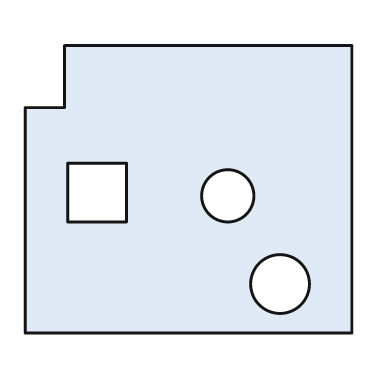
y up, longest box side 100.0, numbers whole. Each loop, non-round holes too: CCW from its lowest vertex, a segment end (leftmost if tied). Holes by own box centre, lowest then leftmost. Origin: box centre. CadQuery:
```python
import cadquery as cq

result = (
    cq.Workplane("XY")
    .moveTo(-50.0, -44.0)
    .lineTo(50.0, -44.0)
    .lineTo(50.0, 44.0)
    .lineTo(-38.0, 44.0)
    .lineTo(-38.0, 25.0)
    .lineTo(-50.0, 25.0)
    .close()
    .moveTo(28.0, -29.0)
    .circle(9.0)
    .moveTo(12.0, -2.0)
    .circle(8.0)
    .moveTo(-37.0, -10.0)
    .lineTo(-19.0, -10.0)
    .lineTo(-19.0, 8.0)
    .lineTo(-37.0, 8.0)
    .close()
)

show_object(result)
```